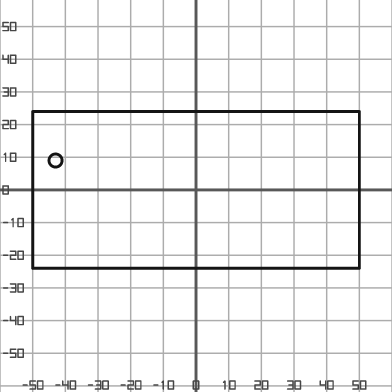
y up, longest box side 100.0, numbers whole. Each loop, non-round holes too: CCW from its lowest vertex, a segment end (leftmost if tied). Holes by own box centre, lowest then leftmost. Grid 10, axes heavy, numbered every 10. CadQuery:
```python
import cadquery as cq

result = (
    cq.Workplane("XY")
    .moveTo(-50.0, -24.0)
    .lineTo(50.0, -24.0)
    .lineTo(50.0, 24.0)
    .lineTo(-50.0, 24.0)
    .close()
    .moveTo(-43.0, 9.0)
    .circle(2.0)
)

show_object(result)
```